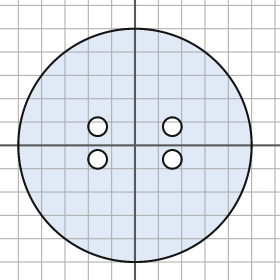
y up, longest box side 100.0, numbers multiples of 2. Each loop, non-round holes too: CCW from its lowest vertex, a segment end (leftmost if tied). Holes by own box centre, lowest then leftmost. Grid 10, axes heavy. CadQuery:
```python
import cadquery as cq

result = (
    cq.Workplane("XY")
    .moveTo(0.0, 0.0)
    .circle(50.0)
    .moveTo(-16.0, -6.0)
    .circle(4.0)
    .moveTo(16.0, -6.0)
    .circle(4.0)
    .moveTo(-16.0, 8.0)
    .circle(4.0)
    .moveTo(16.0, 8.0)
    .circle(4.0)
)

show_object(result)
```